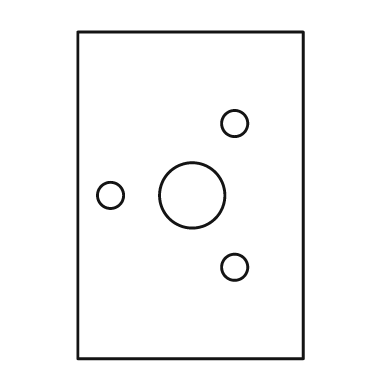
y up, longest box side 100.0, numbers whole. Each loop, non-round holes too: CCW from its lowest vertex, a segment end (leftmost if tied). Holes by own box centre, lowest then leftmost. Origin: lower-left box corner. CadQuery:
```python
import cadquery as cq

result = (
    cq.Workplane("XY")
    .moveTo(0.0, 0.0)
    .lineTo(69.0, 0.0)
    .lineTo(69.0, 100.0)
    .lineTo(0.0, 100.0)
    .close()
    .moveTo(48.0, 28.0)
    .circle(4.0)
    .moveTo(10.0, 50.0)
    .circle(4.0)
    .moveTo(35.0, 50.0)
    .circle(10.0)
    .moveTo(48.0, 72.0)
    .circle(4.0)
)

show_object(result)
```